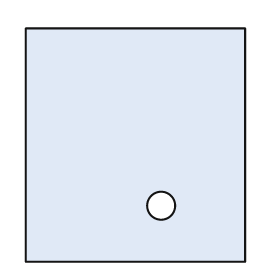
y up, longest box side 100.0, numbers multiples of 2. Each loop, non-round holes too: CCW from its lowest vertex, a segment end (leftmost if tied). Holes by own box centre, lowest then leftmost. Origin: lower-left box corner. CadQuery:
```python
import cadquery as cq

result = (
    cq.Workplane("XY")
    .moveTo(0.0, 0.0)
    .lineTo(94.0, 0.0)
    .lineTo(94.0, 100.0)
    .lineTo(0.0, 100.0)
    .close()
    .moveTo(58.0, 24.0)
    .circle(6.0)
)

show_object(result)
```